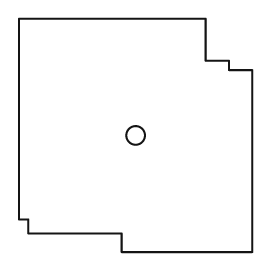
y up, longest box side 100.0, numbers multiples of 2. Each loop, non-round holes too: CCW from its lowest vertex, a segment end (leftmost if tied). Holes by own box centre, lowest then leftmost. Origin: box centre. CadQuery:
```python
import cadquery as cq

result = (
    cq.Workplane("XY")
    .moveTo(-6.0, -50.0)
    .lineTo(50.0, -50.0)
    .lineTo(50.0, 28.0)
    .lineTo(40.0, 28.0)
    .lineTo(40.0, 32.0)
    .lineTo(30.0, 32.0)
    .lineTo(30.0, 50.0)
    .lineTo(-50.0, 50.0)
    .lineTo(-50.0, -36.0)
    .lineTo(-46.0, -36.0)
    .lineTo(-46.0, -42.0)
    .lineTo(-6.0, -42.0)
    .close()
    .moveTo(0.0, 0.0)
    .circle(4.0)
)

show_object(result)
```